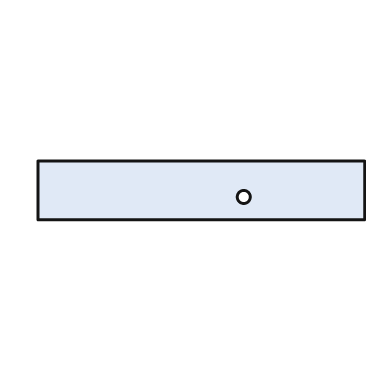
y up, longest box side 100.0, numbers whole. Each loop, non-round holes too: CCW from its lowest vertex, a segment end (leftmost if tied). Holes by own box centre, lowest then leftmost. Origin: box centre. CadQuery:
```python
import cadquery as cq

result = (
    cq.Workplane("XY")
    .moveTo(-50.0, -9.0)
    .lineTo(50.0, -9.0)
    .lineTo(50.0, 9.0)
    .lineTo(-50.0, 9.0)
    .close()
    .moveTo(13.0, -2.0)
    .circle(2.0)
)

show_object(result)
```